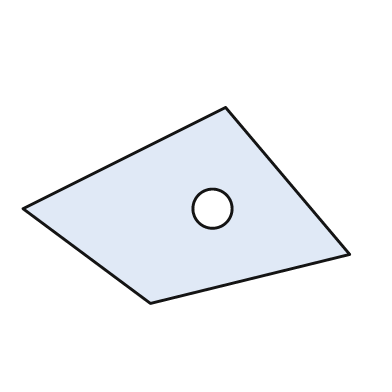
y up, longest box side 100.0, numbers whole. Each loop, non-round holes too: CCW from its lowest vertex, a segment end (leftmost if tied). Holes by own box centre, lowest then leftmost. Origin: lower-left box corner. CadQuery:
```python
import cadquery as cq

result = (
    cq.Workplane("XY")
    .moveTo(39.0, 0.0)
    .lineTo(100.0, 15.0)
    .lineTo(62.0, 60.0)
    .lineTo(0.0, 29.0)
    .close()
    .moveTo(58.0, 29.0)
    .circle(6.0)
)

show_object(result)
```